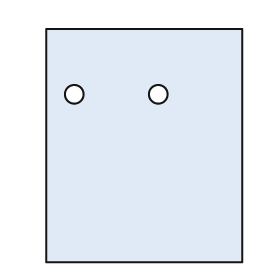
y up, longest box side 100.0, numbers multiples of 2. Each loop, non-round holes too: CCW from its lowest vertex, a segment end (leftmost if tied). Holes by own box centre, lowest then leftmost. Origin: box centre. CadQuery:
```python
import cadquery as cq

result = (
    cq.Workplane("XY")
    .moveTo(-42.0, -50.0)
    .lineTo(42.0, -50.0)
    .lineTo(42.0, 50.0)
    .lineTo(-42.0, 50.0)
    .close()
    .moveTo(-30.0, 22.0)
    .circle(4.0)
    .moveTo(6.0, 22.0)
    .circle(4.0)
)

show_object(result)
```